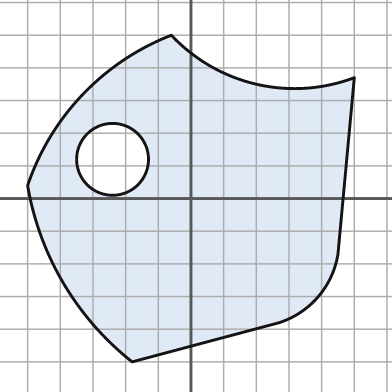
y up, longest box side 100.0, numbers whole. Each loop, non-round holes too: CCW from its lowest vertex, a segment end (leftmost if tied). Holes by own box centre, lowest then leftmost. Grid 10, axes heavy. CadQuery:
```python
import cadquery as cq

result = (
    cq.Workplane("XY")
    .moveTo(-18.0, -50.0)
    .lineTo(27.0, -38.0)
    .threePointArc((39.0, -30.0), (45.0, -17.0))
    .lineTo(50.0, 37.0)
    .threePointArc((20.0, 35.0), (-6.0, 50.0))
    .threePointArc((-33.0, 32.0), (-50.0, 4.0))
    .threePointArc((-39.0, -26.0), (-18.0, -50.0))
    .close()
    .moveTo(-24.0, 12.0)
    .circle(11.0)
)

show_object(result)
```